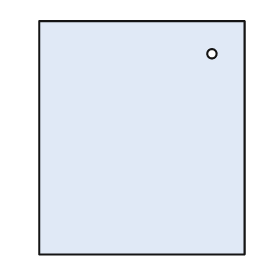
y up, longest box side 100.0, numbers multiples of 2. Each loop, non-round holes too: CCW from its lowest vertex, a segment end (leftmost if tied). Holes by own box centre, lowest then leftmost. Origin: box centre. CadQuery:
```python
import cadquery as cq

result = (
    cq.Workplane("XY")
    .moveTo(-44.0, -50.0)
    .lineTo(44.0, -50.0)
    .lineTo(44.0, 50.0)
    .lineTo(-44.0, 50.0)
    .close()
    .moveTo(30.0, 36.0)
    .circle(2.0)
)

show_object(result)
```